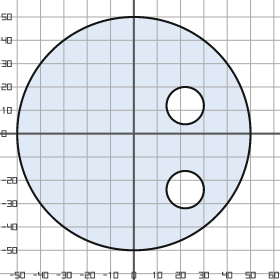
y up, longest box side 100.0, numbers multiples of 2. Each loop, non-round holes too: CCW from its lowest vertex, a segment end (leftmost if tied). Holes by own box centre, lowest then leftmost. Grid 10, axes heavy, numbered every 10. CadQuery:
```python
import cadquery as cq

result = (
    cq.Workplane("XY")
    .moveTo(0.0, 0.0)
    .circle(50.0)
    .moveTo(22.0, -24.0)
    .circle(8.0)
    .moveTo(22.0, 12.0)
    .circle(8.0)
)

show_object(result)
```